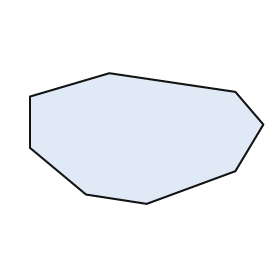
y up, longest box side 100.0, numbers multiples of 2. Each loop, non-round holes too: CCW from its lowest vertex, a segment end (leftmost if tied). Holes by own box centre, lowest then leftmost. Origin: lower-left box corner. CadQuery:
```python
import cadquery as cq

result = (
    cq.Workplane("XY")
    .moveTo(50.0, 0.0)
    .lineTo(88.0, 14.0)
    .lineTo(100.0, 34.0)
    .lineTo(88.0, 48.0)
    .lineTo(34.0, 56.0)
    .lineTo(0.0, 46.0)
    .lineTo(0.0, 24.0)
    .lineTo(24.0, 4.0)
    .close()
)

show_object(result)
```